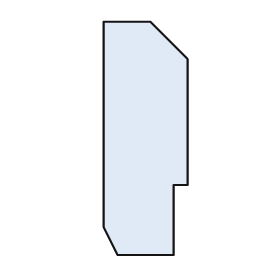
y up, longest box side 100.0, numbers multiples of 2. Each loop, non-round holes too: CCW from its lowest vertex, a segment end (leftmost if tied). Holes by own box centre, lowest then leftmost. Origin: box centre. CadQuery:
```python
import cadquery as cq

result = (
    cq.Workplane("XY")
    .moveTo(-12.0, -50.0)
    .lineTo(12.0, -50.0)
    .lineTo(12.0, -20.0)
    .lineTo(18.0, -20.0)
    .lineTo(18.0, 34.0)
    .lineTo(2.0, 50.0)
    .lineTo(-18.0, 50.0)
    .lineTo(-18.0, -38.0)
    .close()
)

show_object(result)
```